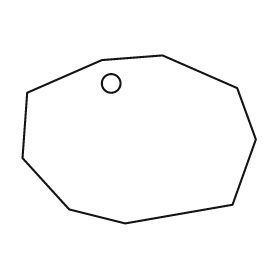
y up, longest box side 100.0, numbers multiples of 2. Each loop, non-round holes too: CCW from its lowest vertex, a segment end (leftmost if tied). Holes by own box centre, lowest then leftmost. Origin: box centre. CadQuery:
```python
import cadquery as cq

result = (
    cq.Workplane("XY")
    .moveTo(-6.0, -36.0)
    .lineTo(40.0, -28.0)
    .lineTo(50.0, 0.0)
    .lineTo(42.0, 22.0)
    .lineTo(10.0, 36.0)
    .lineTo(-16.0, 34.0)
    .lineTo(-48.0, 20.0)
    .lineTo(-50.0, -8.0)
    .lineTo(-30.0, -30.0)
    .close()
    .moveTo(-12.0, 24.0)
    .circle(4.0)
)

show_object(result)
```